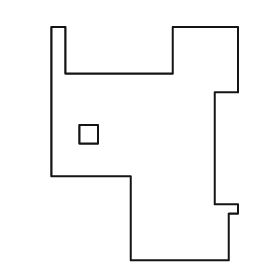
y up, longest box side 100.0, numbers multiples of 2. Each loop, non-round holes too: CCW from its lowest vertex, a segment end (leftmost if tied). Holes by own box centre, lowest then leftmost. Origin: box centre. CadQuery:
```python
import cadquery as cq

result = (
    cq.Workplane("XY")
    .moveTo(-6.0, -50.0)
    .lineTo(36.0, -50.0)
    .lineTo(36.0, -30.0)
    .lineTo(40.0, -30.0)
    .lineTo(40.0, -26.0)
    .lineTo(30.0, -26.0)
    .lineTo(30.0, 22.0)
    .lineTo(40.0, 22.0)
    .lineTo(40.0, 50.0)
    .lineTo(12.0, 50.0)
    .lineTo(12.0, 30.0)
    .lineTo(-34.0, 30.0)
    .lineTo(-34.0, 50.0)
    .lineTo(-40.0, 50.0)
    .lineTo(-40.0, -14.0)
    .lineTo(-6.0, -14.0)
    .close()
    .moveTo(-28.0, 0.0)
    .lineTo(-20.0, 0.0)
    .lineTo(-20.0, 8.0)
    .lineTo(-28.0, 8.0)
    .close()
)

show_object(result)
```